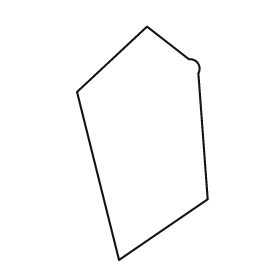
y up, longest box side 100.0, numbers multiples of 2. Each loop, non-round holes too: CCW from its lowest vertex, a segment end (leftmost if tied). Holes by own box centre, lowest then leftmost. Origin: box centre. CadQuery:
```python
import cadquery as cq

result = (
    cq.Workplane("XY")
    .moveTo(-10.0, -50.0)
    .lineTo(28.0, -24.0)
    .lineTo(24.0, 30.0)
    .threePointArc((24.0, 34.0), (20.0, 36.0))
    .lineTo(2.0, 50.0)
    .lineTo(-28.0, 22.0)
    .close()
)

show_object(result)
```